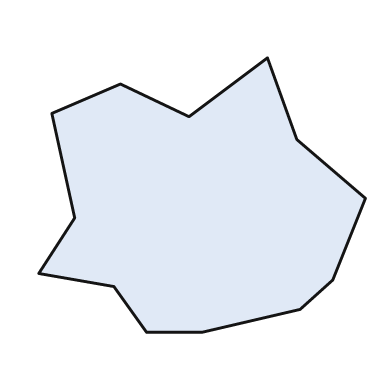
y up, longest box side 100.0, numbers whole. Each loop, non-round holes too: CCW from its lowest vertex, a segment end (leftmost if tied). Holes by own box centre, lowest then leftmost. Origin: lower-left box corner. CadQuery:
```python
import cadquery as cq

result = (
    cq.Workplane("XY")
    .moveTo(33.0, 0.0)
    .lineTo(50.0, 0.0)
    .lineTo(80.0, 7.0)
    .lineTo(90.0, 16.0)
    .lineTo(100.0, 41.0)
    .lineTo(79.0, 59.0)
    .lineTo(70.0, 84.0)
    .lineTo(46.0, 66.0)
    .lineTo(25.0, 76.0)
    .lineTo(4.0, 67.0)
    .lineTo(11.0, 35.0)
    .lineTo(0.0, 18.0)
    .lineTo(23.0, 14.0)
    .close()
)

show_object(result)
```